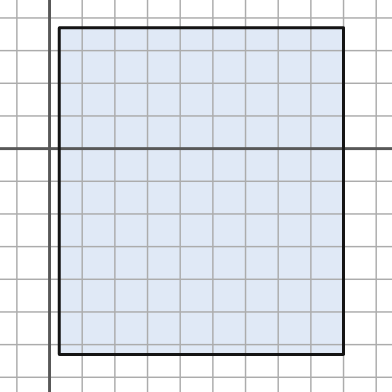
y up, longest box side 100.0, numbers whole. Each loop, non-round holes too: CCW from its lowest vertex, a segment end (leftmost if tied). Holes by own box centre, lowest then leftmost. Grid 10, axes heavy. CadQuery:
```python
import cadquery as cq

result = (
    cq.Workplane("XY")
    .moveTo(3.0, -63.0)
    .lineTo(90.0, -63.0)
    .lineTo(90.0, 37.0)
    .lineTo(3.0, 37.0)
    .close()
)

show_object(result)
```